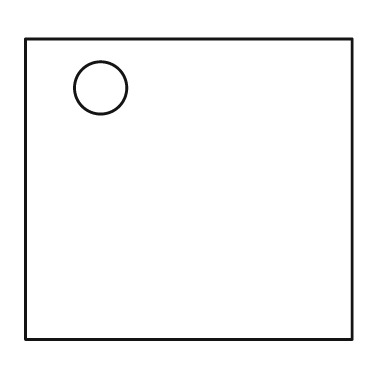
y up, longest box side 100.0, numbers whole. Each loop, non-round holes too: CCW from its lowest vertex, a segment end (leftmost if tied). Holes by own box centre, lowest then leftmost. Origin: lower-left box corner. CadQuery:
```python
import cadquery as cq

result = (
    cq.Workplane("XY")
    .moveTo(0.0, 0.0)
    .lineTo(100.0, 0.0)
    .lineTo(100.0, 92.0)
    .lineTo(0.0, 92.0)
    .close()
    .moveTo(23.0, 77.0)
    .circle(8.0)
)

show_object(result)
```